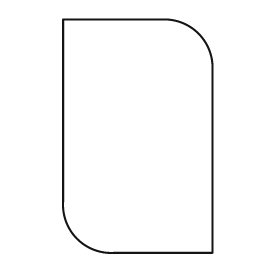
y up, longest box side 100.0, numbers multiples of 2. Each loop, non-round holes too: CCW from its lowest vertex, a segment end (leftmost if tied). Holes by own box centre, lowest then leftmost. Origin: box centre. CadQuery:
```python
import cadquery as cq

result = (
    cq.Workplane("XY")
    .moveTo(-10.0, -50.0)
    .lineTo(32.0, -50.0)
    .lineTo(32.0, 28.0)
    .threePointArc((26.0, 44.0), (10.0, 50.0))
    .lineTo(-32.0, 50.0)
    .lineTo(-32.0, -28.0)
    .threePointArc((-26.0, -44.0), (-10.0, -50.0))
    .close()
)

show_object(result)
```